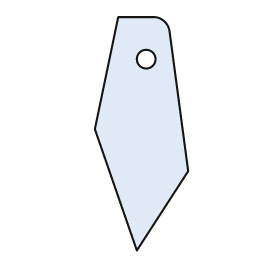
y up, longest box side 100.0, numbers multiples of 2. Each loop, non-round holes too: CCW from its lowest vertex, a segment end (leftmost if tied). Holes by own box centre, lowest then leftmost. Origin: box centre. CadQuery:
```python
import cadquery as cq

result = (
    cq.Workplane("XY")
    .moveTo(-2.0, -50.0)
    .lineTo(20.0, -16.0)
    .lineTo(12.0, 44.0)
    .threePointArc((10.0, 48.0), (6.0, 50.0))
    .lineTo(-10.0, 50.0)
    .lineTo(-20.0, 2.0)
    .close()
    .moveTo(2.0, 32.0)
    .circle(4.0)
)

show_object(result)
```